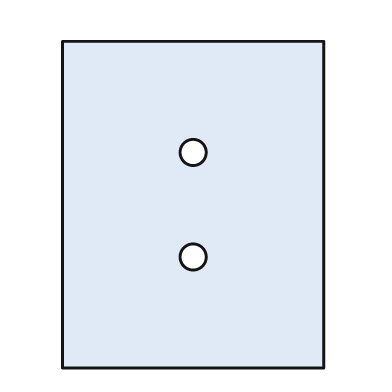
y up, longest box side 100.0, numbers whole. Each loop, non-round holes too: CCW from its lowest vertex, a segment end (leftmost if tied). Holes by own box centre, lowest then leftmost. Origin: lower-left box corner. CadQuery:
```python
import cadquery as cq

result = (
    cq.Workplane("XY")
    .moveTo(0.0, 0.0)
    .lineTo(80.0, 0.0)
    .lineTo(80.0, 100.0)
    .lineTo(0.0, 100.0)
    .close()
    .moveTo(40.0, 34.0)
    .circle(4.0)
    .moveTo(40.0, 66.0)
    .circle(4.0)
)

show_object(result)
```